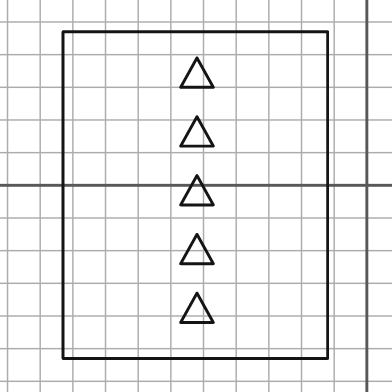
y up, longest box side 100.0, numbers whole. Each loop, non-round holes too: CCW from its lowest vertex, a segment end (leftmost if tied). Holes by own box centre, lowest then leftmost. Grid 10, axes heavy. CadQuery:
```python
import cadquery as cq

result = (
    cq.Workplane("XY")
    .moveTo(-93.0, -53.0)
    .lineTo(-12.0, -53.0)
    .lineTo(-12.0, 47.0)
    .lineTo(-93.0, 47.0)
    .close()
    .moveTo(-57.0, -42.0)
    .lineTo(-47.0, -42.0)
    .lineTo(-52.0, -33.0)
    .close()
    .moveTo(-57.0, -24.0)
    .lineTo(-47.0, -24.0)
    .lineTo(-52.0, -15.0)
    .close()
    .moveTo(-57.0, -6.0)
    .lineTo(-47.0, -6.0)
    .lineTo(-52.0, 3.0)
    .close()
    .moveTo(-57.0, 12.0)
    .lineTo(-47.0, 12.0)
    .lineTo(-52.0, 21.0)
    .close()
    .moveTo(-57.0, 30.0)
    .lineTo(-47.0, 30.0)
    .lineTo(-52.0, 39.0)
    .close()
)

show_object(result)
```